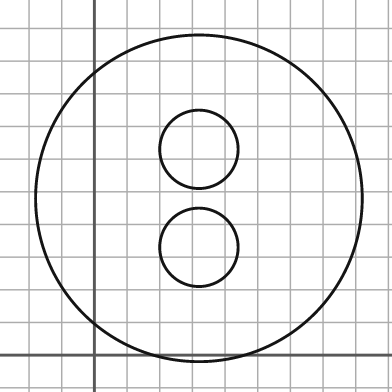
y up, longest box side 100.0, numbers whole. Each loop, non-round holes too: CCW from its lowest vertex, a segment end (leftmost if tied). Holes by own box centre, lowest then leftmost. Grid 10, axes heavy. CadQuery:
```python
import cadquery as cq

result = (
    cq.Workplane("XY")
    .moveTo(32.0, 48.0)
    .circle(50.0)
    .moveTo(32.0, 33.0)
    .circle(12.0)
    .moveTo(32.0, 63.0)
    .circle(12.0)
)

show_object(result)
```